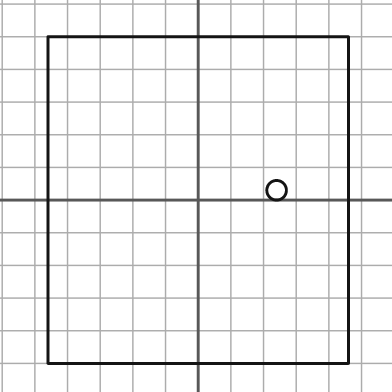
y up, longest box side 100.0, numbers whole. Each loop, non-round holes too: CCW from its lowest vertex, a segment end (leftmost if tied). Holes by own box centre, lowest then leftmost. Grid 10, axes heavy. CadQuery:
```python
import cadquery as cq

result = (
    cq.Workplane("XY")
    .moveTo(-46.0, -50.0)
    .lineTo(46.0, -50.0)
    .lineTo(46.0, 50.0)
    .lineTo(-46.0, 50.0)
    .close()
    .moveTo(24.0, 3.0)
    .circle(3.0)
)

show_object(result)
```